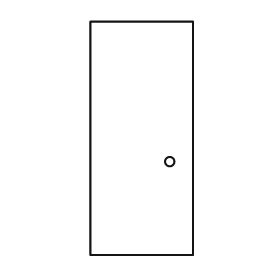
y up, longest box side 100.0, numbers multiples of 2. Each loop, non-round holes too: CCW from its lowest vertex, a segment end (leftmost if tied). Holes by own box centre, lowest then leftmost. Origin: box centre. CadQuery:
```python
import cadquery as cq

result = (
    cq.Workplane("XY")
    .moveTo(-22.0, -50.0)
    .lineTo(22.0, -50.0)
    .lineTo(22.0, 50.0)
    .lineTo(-22.0, 50.0)
    .close()
    .moveTo(12.0, -10.0)
    .circle(2.0)
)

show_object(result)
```